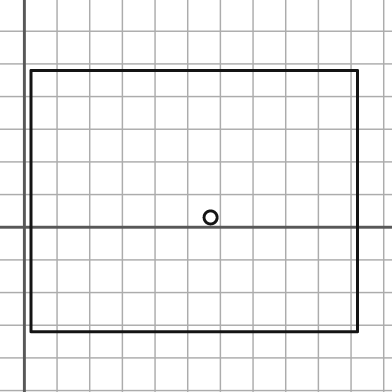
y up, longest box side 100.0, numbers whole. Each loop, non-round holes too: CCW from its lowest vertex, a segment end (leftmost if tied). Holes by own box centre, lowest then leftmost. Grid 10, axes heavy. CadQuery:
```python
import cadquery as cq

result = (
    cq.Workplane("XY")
    .moveTo(2.0, -32.0)
    .lineTo(102.0, -32.0)
    .lineTo(102.0, 48.0)
    .lineTo(2.0, 48.0)
    .close()
    .moveTo(57.0, 3.0)
    .circle(2.0)
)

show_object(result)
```